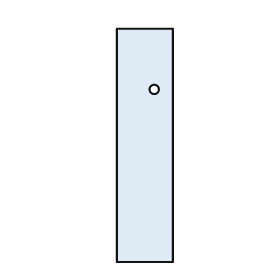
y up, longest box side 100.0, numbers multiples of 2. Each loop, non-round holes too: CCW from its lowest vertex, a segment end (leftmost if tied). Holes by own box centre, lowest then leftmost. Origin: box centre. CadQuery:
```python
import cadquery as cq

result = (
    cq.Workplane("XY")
    .moveTo(-12.0, -50.0)
    .lineTo(12.0, -50.0)
    .lineTo(12.0, 50.0)
    .lineTo(-12.0, 50.0)
    .close()
    .moveTo(4.0, 24.0)
    .circle(2.0)
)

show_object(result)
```